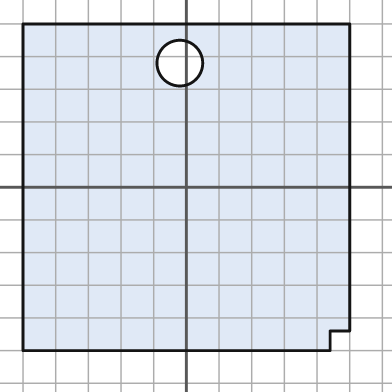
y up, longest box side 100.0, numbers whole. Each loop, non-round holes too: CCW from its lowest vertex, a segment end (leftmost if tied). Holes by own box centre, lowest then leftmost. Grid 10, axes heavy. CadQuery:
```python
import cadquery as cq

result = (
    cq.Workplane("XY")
    .moveTo(-50.0, -50.0)
    .lineTo(44.0, -50.0)
    .lineTo(44.0, -44.0)
    .lineTo(50.0, -44.0)
    .lineTo(50.0, 50.0)
    .lineTo(-50.0, 50.0)
    .close()
    .moveTo(-2.0, 38.0)
    .circle(7.0)
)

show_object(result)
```